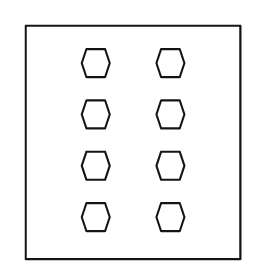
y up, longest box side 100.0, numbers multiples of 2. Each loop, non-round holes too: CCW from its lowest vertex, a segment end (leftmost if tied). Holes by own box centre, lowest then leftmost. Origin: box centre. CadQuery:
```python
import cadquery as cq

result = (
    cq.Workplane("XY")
    .moveTo(-46.0, -50.0)
    .lineTo(46.0, -50.0)
    .lineTo(46.0, 50.0)
    .lineTo(-46.0, 50.0)
    .close()
    .moveTo(-20.0, -38.0)
    .lineTo(-12.0, -38.0)
    .lineTo(-10.0, -32.0)
    .lineTo(-12.0, -26.0)
    .lineTo(-20.0, -26.0)
    .lineTo(-22.0, -32.0)
    .close()
    .moveTo(12.0, -38.0)
    .lineTo(20.0, -38.0)
    .lineTo(22.0, -32.0)
    .lineTo(20.0, -26.0)
    .lineTo(12.0, -26.0)
    .lineTo(10.0, -32.0)
    .close()
    .moveTo(-20.0, -16.0)
    .lineTo(-12.0, -16.0)
    .lineTo(-10.0, -10.0)
    .lineTo(-12.0, -4.0)
    .lineTo(-20.0, -4.0)
    .lineTo(-22.0, -10.0)
    .close()
    .moveTo(12.0, -16.0)
    .lineTo(20.0, -16.0)
    .lineTo(22.0, -10.0)
    .lineTo(20.0, -4.0)
    .lineTo(12.0, -4.0)
    .lineTo(10.0, -10.0)
    .close()
    .moveTo(-20.0, 6.0)
    .lineTo(-12.0, 6.0)
    .lineTo(-10.0, 12.0)
    .lineTo(-12.0, 18.0)
    .lineTo(-20.0, 18.0)
    .lineTo(-22.0, 12.0)
    .close()
    .moveTo(12.0, 6.0)
    .lineTo(20.0, 6.0)
    .lineTo(22.0, 12.0)
    .lineTo(20.0, 18.0)
    .lineTo(12.0, 18.0)
    .lineTo(10.0, 12.0)
    .close()
    .moveTo(-20.0, 28.0)
    .lineTo(-12.0, 28.0)
    .lineTo(-10.0, 34.0)
    .lineTo(-12.0, 40.0)
    .lineTo(-20.0, 40.0)
    .lineTo(-22.0, 34.0)
    .close()
    .moveTo(12.0, 28.0)
    .lineTo(20.0, 28.0)
    .lineTo(22.0, 34.0)
    .lineTo(20.0, 40.0)
    .lineTo(12.0, 40.0)
    .lineTo(10.0, 34.0)
    .close()
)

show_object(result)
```